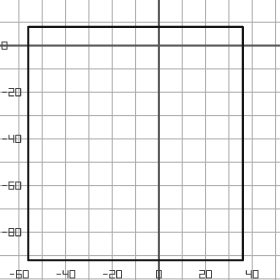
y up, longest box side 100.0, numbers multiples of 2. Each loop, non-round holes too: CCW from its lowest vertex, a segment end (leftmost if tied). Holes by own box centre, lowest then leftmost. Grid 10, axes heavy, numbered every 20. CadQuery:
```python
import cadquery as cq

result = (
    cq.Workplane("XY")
    .moveTo(-56.0, -92.0)
    .lineTo(36.0, -92.0)
    .lineTo(36.0, 8.0)
    .lineTo(-56.0, 8.0)
    .close()
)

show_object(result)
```